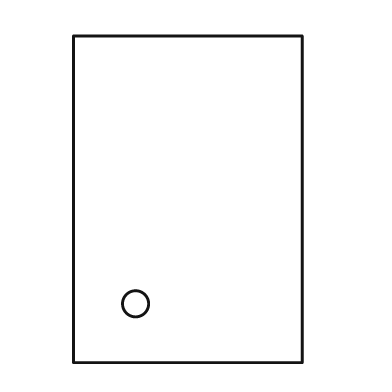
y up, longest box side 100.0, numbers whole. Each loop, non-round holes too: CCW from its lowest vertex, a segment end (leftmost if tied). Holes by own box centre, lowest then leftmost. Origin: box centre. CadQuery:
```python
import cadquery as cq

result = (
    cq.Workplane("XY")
    .moveTo(-35.0, -50.0)
    .lineTo(35.0, -50.0)
    .lineTo(35.0, 50.0)
    .lineTo(-35.0, 50.0)
    .close()
    .moveTo(-16.0, -32.0)
    .circle(4.0)
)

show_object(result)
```